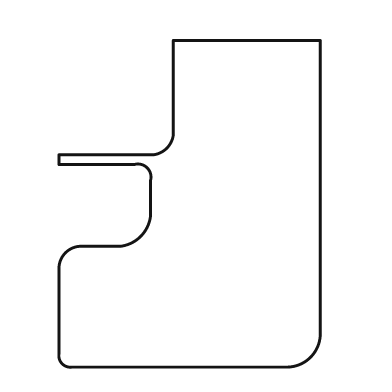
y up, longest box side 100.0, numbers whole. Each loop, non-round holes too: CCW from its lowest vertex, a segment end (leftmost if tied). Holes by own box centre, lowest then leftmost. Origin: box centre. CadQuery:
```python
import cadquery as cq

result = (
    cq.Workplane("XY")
    .moveTo(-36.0, -50.0)
    .lineTo(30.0, -50.0)
    .threePointArc((37.0, -47.0), (40.0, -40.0))
    .lineTo(40.0, 50.0)
    .lineTo(-5.0, 50.0)
    .lineTo(-5.0, 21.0)
    .threePointArc((-7.0, 17.0), (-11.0, 15.0))
    .lineTo(-40.0, 15.0)
    .lineTo(-40.0, 12.0)
    .lineTo(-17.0, 12.0)
    .threePointArc((-13.0, 11.0), (-12.0, 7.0))
    .lineTo(-12.0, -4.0)
    .threePointArc((-15.0, -10.0), (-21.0, -13.0))
    .lineTo(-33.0, -13.0)
    .threePointArc((-38.0, -15.0), (-40.0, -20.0))
    .lineTo(-40.0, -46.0)
    .threePointArc((-39.0, -49.0), (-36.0, -50.0))
    .close()
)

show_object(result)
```